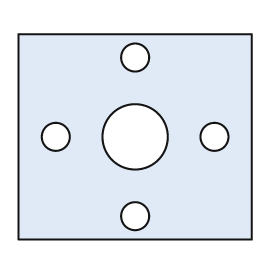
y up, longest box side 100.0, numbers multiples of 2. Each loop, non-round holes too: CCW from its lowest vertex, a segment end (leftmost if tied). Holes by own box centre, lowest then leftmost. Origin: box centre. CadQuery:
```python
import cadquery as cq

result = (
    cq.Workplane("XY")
    .moveTo(-50.0, -44.0)
    .lineTo(50.0, -44.0)
    .lineTo(50.0, 44.0)
    .lineTo(-50.0, 44.0)
    .close()
    .moveTo(0.0, -34.0)
    .circle(6.0)
    .moveTo(-34.0, 0.0)
    .circle(6.0)
    .moveTo(0.0, 0.0)
    .circle(14.0)
    .moveTo(34.0, 0.0)
    .circle(6.0)
    .moveTo(0.0, 34.0)
    .circle(6.0)
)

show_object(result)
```